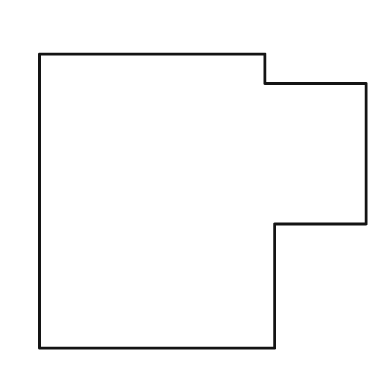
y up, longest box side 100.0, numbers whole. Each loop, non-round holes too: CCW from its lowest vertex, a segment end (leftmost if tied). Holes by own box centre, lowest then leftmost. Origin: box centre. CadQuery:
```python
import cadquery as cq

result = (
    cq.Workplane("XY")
    .moveTo(-50.0, -45.0)
    .lineTo(22.0, -45.0)
    .lineTo(22.0, -7.0)
    .lineTo(50.0, -7.0)
    .lineTo(50.0, 36.0)
    .lineTo(19.0, 36.0)
    .lineTo(19.0, 45.0)
    .lineTo(-50.0, 45.0)
    .close()
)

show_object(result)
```